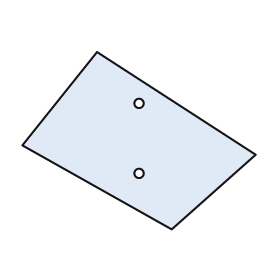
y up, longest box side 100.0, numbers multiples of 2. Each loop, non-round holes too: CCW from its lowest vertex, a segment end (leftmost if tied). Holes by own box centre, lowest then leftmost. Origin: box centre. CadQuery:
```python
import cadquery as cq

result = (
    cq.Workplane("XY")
    .moveTo(14.0, -38.0)
    .lineTo(50.0, -6.0)
    .lineTo(-18.0, 38.0)
    .lineTo(-50.0, -2.0)
    .close()
    .moveTo(0.0, -14.0)
    .circle(2.0)
    .moveTo(0.0, 16.0)
    .circle(2.0)
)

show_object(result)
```